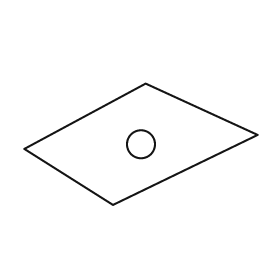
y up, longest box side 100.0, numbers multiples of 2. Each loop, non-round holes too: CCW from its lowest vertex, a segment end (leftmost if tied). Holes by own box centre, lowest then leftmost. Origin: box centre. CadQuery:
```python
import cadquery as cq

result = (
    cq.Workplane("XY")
    .moveTo(-12.0, -26.0)
    .lineTo(50.0, 4.0)
    .lineTo(2.0, 26.0)
    .lineTo(-50.0, -2.0)
    .close()
    .moveTo(0.0, 0.0)
    .circle(6.0)
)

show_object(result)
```